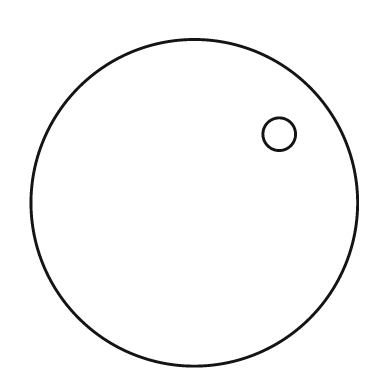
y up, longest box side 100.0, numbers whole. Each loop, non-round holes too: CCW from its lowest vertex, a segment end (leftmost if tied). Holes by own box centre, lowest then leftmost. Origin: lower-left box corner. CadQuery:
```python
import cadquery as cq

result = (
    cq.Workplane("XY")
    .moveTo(50.0, 50.0)
    .circle(50.0)
    .moveTo(76.0, 71.0)
    .circle(5.0)
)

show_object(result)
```